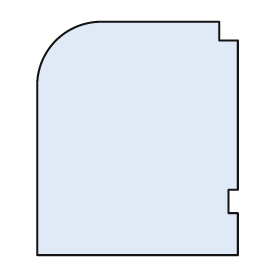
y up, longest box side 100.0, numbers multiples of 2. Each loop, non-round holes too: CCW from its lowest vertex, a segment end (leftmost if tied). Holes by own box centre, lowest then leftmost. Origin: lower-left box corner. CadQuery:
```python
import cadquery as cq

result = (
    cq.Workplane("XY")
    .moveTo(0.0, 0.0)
    .lineTo(86.0, 0.0)
    .lineTo(86.0, 18.0)
    .lineTo(82.0, 18.0)
    .lineTo(82.0, 28.0)
    .lineTo(86.0, 28.0)
    .lineTo(86.0, 92.0)
    .lineTo(78.0, 92.0)
    .lineTo(78.0, 100.0)
    .lineTo(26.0, 100.0)
    .threePointArc((8.0, 92.0), (0.0, 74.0))
    .close()
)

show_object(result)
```